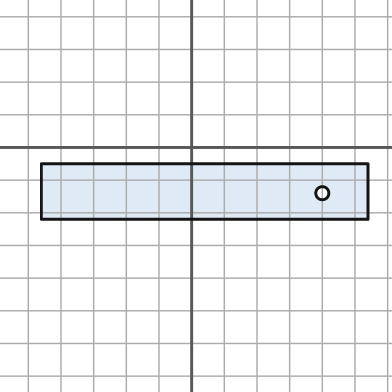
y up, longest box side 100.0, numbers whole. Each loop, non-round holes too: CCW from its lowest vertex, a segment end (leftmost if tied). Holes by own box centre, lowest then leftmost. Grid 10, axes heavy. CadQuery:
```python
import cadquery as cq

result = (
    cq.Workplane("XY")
    .moveTo(-46.0, -22.0)
    .lineTo(54.0, -22.0)
    .lineTo(54.0, -5.0)
    .lineTo(-46.0, -5.0)
    .close()
    .moveTo(40.0, -14.0)
    .circle(2.0)
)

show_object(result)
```